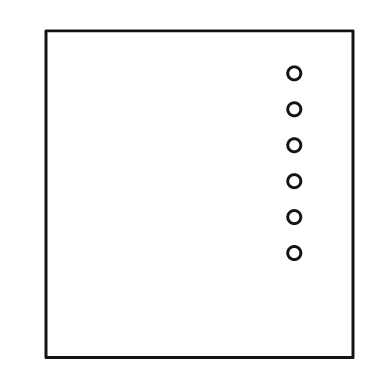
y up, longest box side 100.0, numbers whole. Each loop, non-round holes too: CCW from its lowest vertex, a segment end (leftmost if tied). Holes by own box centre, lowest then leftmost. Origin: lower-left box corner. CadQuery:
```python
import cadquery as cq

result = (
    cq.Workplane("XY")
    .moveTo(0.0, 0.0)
    .lineTo(94.0, 0.0)
    .lineTo(94.0, 100.0)
    .lineTo(0.0, 100.0)
    .close()
    .moveTo(76.0, 32.0)
    .circle(2.0)
    .moveTo(76.0, 43.0)
    .circle(2.0)
    .moveTo(76.0, 54.0)
    .circle(2.0)
    .moveTo(76.0, 65.0)
    .circle(2.0)
    .moveTo(76.0, 76.0)
    .circle(2.0)
    .moveTo(76.0, 87.0)
    .circle(2.0)
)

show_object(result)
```